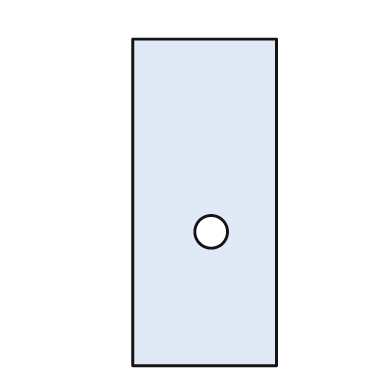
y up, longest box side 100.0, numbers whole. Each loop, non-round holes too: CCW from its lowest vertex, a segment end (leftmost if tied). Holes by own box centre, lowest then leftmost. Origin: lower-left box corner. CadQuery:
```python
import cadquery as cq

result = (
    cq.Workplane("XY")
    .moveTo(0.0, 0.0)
    .lineTo(44.0, 0.0)
    .lineTo(44.0, 100.0)
    .lineTo(0.0, 100.0)
    .close()
    .moveTo(24.0, 41.0)
    .circle(5.0)
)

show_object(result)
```